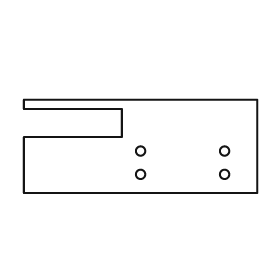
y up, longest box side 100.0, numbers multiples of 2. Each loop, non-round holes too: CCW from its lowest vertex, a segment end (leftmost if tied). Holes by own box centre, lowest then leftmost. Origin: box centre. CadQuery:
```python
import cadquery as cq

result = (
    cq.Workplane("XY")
    .moveTo(-50.0, -20.0)
    .lineTo(50.0, -20.0)
    .lineTo(50.0, 20.0)
    .lineTo(-50.0, 20.0)
    .lineTo(-50.0, 16.0)
    .lineTo(-8.0, 16.0)
    .lineTo(-8.0, 4.0)
    .lineTo(-50.0, 4.0)
    .close()
    .moveTo(0.0, -12.0)
    .circle(2.0)
    .moveTo(36.0, -12.0)
    .circle(2.0)
    .moveTo(0.0, -2.0)
    .circle(2.0)
    .moveTo(36.0, -2.0)
    .circle(2.0)
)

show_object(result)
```